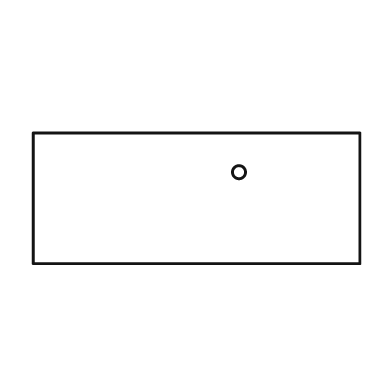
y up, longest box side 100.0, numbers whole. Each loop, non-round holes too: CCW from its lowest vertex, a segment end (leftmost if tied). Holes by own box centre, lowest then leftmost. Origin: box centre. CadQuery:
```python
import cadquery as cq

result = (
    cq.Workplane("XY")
    .moveTo(-50.0, -20.0)
    .lineTo(50.0, -20.0)
    .lineTo(50.0, 20.0)
    .lineTo(-50.0, 20.0)
    .close()
    .moveTo(13.0, 8.0)
    .circle(2.0)
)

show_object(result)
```